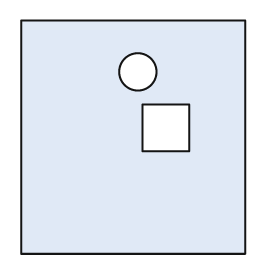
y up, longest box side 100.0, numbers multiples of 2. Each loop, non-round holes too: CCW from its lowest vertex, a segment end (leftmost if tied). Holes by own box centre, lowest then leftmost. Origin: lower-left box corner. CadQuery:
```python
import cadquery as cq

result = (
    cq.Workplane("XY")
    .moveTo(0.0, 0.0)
    .lineTo(96.0, 0.0)
    .lineTo(96.0, 100.0)
    .lineTo(0.0, 100.0)
    .close()
    .moveTo(52.0, 44.0)
    .lineTo(72.0, 44.0)
    .lineTo(72.0, 64.0)
    .lineTo(52.0, 64.0)
    .close()
    .moveTo(50.0, 78.0)
    .circle(8.0)
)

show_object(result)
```